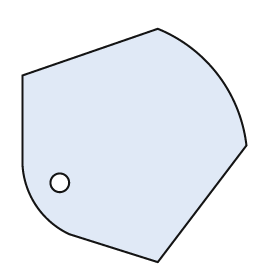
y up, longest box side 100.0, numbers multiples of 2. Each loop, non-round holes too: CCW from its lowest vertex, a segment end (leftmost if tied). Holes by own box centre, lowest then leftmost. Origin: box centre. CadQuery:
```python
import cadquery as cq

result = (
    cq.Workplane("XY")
    .moveTo(10.0, -50.0)
    .lineTo(48.0, 0.0)
    .threePointArc((36.0, 30.0), (10.0, 50.0))
    .lineTo(-48.0, 30.0)
    .lineTo(-48.0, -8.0)
    .threePointArc((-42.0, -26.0), (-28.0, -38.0))
    .close()
    .moveTo(-32.0, -16.0)
    .circle(4.0)
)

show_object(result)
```